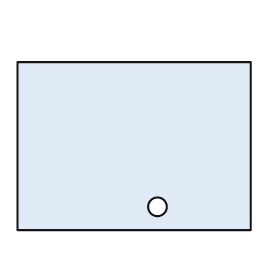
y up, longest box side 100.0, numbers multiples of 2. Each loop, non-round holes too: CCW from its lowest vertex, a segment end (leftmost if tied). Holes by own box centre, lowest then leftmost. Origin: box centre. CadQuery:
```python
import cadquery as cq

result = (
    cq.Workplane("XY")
    .moveTo(-50.0, -36.0)
    .lineTo(50.0, -36.0)
    .lineTo(50.0, 36.0)
    .lineTo(-50.0, 36.0)
    .close()
    .moveTo(10.0, -26.0)
    .circle(4.0)
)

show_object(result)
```